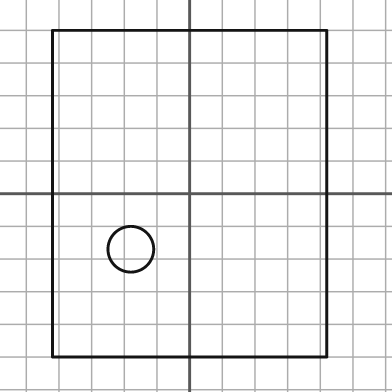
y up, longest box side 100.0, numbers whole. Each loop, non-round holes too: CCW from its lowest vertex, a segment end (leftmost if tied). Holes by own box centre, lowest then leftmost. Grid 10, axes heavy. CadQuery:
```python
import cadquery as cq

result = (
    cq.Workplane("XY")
    .moveTo(-42.0, -50.0)
    .lineTo(42.0, -50.0)
    .lineTo(42.0, 50.0)
    .lineTo(-42.0, 50.0)
    .close()
    .moveTo(-18.0, -17.0)
    .circle(7.0)
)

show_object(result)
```